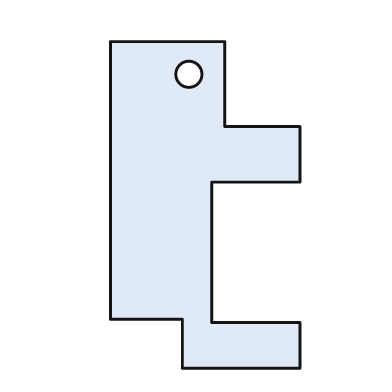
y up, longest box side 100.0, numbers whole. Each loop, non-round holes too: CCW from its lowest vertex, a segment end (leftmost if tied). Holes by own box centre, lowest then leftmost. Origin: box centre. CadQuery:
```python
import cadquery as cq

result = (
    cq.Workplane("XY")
    .moveTo(-7.0, -50.0)
    .lineTo(29.0, -50.0)
    .lineTo(29.0, -36.0)
    .lineTo(2.0, -36.0)
    .lineTo(2.0, 7.0)
    .lineTo(29.0, 7.0)
    .lineTo(29.0, 24.0)
    .lineTo(6.0, 24.0)
    .lineTo(6.0, 50.0)
    .lineTo(-29.0, 50.0)
    .lineTo(-29.0, -35.0)
    .lineTo(-7.0, -35.0)
    .close()
    .moveTo(-5.0, 40.0)
    .circle(4.0)
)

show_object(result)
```